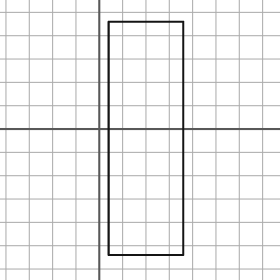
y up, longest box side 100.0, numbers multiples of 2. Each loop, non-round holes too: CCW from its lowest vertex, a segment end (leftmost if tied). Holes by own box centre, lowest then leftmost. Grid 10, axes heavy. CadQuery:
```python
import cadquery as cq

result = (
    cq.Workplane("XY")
    .moveTo(4.0, -54.0)
    .lineTo(36.0, -54.0)
    .lineTo(36.0, 46.0)
    .lineTo(4.0, 46.0)
    .close()
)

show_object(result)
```